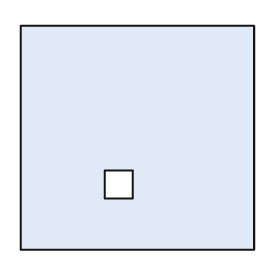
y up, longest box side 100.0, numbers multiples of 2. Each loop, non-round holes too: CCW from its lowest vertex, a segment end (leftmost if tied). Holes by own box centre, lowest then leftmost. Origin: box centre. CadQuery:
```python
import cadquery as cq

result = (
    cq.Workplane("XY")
    .moveTo(-50.0, -48.0)
    .lineTo(50.0, -48.0)
    .lineTo(50.0, 48.0)
    .lineTo(-50.0, 48.0)
    .close()
    .moveTo(-14.0, -26.0)
    .lineTo(-2.0, -26.0)
    .lineTo(-2.0, -14.0)
    .lineTo(-14.0, -14.0)
    .close()
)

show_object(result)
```